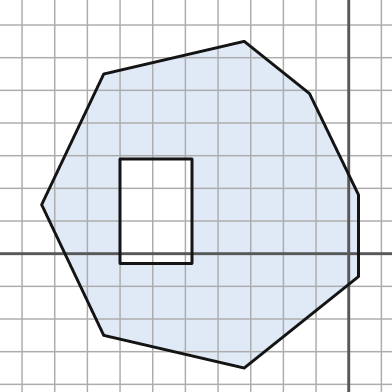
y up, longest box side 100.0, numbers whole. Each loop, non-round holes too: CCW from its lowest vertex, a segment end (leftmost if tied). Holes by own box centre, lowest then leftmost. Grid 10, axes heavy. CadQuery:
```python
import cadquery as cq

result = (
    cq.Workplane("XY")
    .moveTo(-32.0, -35.0)
    .lineTo(3.0, -7.0)
    .lineTo(3.0, 18.0)
    .lineTo(-12.0, 49.0)
    .lineTo(-32.0, 65.0)
    .lineTo(-75.0, 55.0)
    .lineTo(-94.0, 15.0)
    .lineTo(-75.0, -25.0)
    .close()
    .moveTo(-70.0, -3.0)
    .lineTo(-48.0, -3.0)
    .lineTo(-48.0, 29.0)
    .lineTo(-70.0, 29.0)
    .close()
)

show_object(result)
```